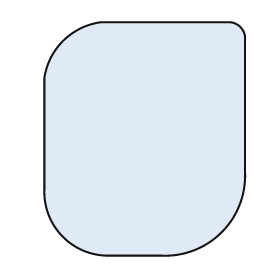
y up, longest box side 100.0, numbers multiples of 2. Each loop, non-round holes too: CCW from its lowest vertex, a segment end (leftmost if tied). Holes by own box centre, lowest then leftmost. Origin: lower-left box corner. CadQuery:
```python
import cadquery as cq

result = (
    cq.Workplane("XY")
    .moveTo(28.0, 0.0)
    .lineTo(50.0, 0.0)
    .threePointArc((76.0, 10.0), (86.0, 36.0))
    .lineTo(86.0, 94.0)
    .threePointArc((84.0, 98.0), (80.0, 100.0))
    .lineTo(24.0, 100.0)
    .threePointArc((8.0, 92.0), (0.0, 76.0))
    .lineTo(0.0, 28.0)
    .threePointArc((8.0, 8.0), (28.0, 0.0))
    .close()
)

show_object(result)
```